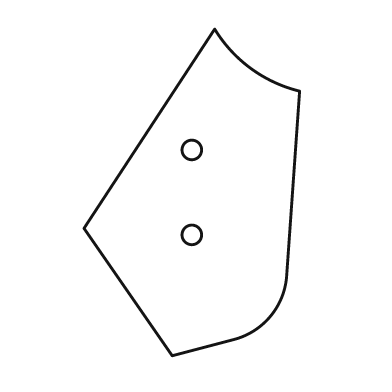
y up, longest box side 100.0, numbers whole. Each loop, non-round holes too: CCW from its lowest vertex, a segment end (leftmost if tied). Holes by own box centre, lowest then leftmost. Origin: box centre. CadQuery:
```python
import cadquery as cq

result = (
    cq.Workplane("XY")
    .moveTo(-6.0, -50.0)
    .lineTo(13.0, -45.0)
    .threePointArc((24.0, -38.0), (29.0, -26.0))
    .lineTo(33.0, 31.0)
    .threePointArc((18.0, 38.0), (7.0, 50.0))
    .lineTo(-33.0, -11.0)
    .close()
    .moveTo(0.0, -13.0)
    .circle(3.0)
    .moveTo(0.0, 13.0)
    .circle(3.0)
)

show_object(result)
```